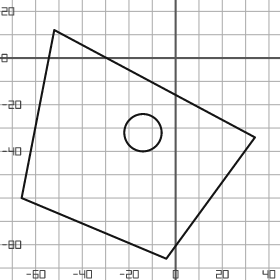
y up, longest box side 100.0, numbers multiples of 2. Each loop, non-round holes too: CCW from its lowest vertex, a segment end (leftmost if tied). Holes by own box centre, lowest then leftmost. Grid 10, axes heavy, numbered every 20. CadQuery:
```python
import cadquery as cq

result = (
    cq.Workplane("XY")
    .moveTo(-4.0, -86.0)
    .lineTo(34.0, -34.0)
    .lineTo(-52.0, 12.0)
    .lineTo(-66.0, -60.0)
    .close()
    .moveTo(-14.0, -32.0)
    .circle(8.0)
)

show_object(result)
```